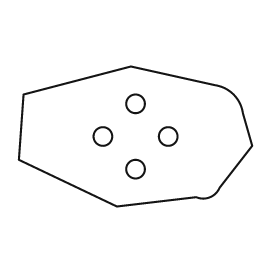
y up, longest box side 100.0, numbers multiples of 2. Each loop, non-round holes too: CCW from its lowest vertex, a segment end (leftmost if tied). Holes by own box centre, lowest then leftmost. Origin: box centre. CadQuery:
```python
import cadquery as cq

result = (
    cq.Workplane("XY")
    .moveTo(-8.0, -30.0)
    .lineTo(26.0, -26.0)
    .threePointArc((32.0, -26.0), (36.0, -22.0))
    .lineTo(50.0, -4.0)
    .lineTo(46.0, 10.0)
    .threePointArc((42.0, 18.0), (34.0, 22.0))
    .lineTo(-2.0, 30.0)
    .lineTo(-48.0, 18.0)
    .lineTo(-50.0, -10.0)
    .close()
    .moveTo(0.0, -14.0)
    .circle(4.0)
    .moveTo(-14.0, 0.0)
    .circle(4.0)
    .moveTo(14.0, 0.0)
    .circle(4.0)
    .moveTo(0.0, 14.0)
    .circle(4.0)
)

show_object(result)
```